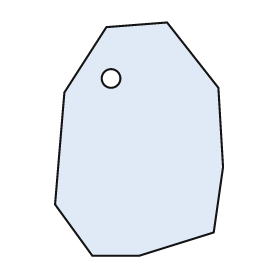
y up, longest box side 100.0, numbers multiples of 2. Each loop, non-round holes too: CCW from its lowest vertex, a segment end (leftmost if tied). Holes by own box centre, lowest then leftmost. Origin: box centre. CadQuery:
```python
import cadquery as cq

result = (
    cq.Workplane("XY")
    .moveTo(-20.0, -50.0)
    .lineTo(0.0, -50.0)
    .lineTo(32.0, -40.0)
    .lineTo(36.0, -12.0)
    .lineTo(34.0, 22.0)
    .lineTo(12.0, 50.0)
    .lineTo(-14.0, 48.0)
    .lineTo(-32.0, 20.0)
    .lineTo(-36.0, -28.0)
    .close()
    .moveTo(-12.0, 26.0)
    .circle(4.0)
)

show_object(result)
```